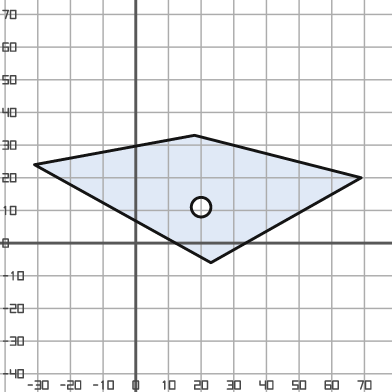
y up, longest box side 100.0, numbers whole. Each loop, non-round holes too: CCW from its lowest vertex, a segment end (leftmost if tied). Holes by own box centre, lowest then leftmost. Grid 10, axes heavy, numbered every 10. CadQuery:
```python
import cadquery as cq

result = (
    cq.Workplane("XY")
    .moveTo(23.0, -6.0)
    .lineTo(69.0, 20.0)
    .lineTo(18.0, 33.0)
    .lineTo(-31.0, 24.0)
    .close()
    .moveTo(20.0, 11.0)
    .circle(3.0)
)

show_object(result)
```